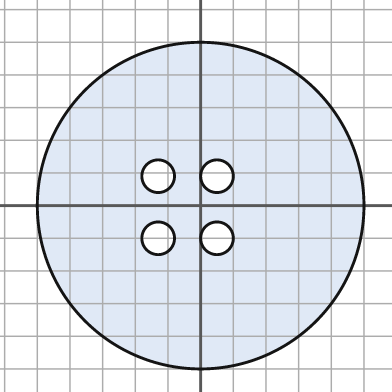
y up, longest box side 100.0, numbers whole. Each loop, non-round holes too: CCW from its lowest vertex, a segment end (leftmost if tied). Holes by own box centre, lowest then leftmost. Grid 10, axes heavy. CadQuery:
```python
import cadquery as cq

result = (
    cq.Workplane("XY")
    .moveTo(0.0, 0.0)
    .circle(50.0)
    .moveTo(-13.0, -10.0)
    .circle(5.0)
    .moveTo(5.0, -10.0)
    .circle(5.0)
    .moveTo(-13.0, 9.0)
    .circle(5.0)
    .moveTo(5.0, 9.0)
    .circle(5.0)
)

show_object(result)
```